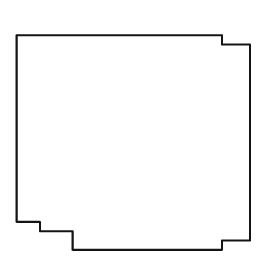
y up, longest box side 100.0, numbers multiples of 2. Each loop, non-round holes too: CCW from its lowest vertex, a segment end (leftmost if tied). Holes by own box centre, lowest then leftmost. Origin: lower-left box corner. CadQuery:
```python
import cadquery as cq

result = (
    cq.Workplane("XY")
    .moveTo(24.0, 0.0)
    .lineTo(88.0, 0.0)
    .lineTo(88.0, 4.0)
    .lineTo(100.0, 4.0)
    .lineTo(100.0, 88.0)
    .lineTo(88.0, 88.0)
    .lineTo(88.0, 92.0)
    .lineTo(0.0, 92.0)
    .lineTo(0.0, 12.0)
    .lineTo(10.0, 12.0)
    .lineTo(10.0, 8.0)
    .lineTo(24.0, 8.0)
    .close()
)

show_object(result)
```